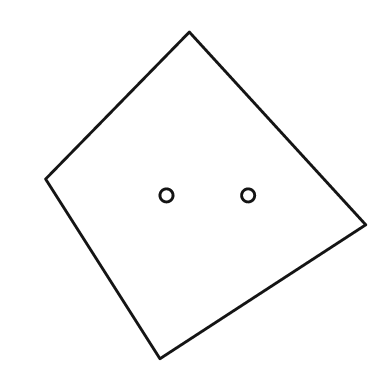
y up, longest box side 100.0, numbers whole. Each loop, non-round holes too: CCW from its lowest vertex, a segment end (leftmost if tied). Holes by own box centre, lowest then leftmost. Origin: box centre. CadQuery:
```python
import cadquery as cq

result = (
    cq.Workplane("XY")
    .moveTo(-14.0, -50.0)
    .lineTo(49.0, -9.0)
    .lineTo(-5.0, 50.0)
    .lineTo(-49.0, 5.0)
    .close()
    .moveTo(-12.0, 0.0)
    .circle(2.0)
    .moveTo(13.0, 0.0)
    .circle(2.0)
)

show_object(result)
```